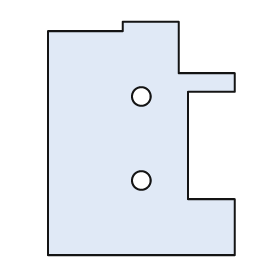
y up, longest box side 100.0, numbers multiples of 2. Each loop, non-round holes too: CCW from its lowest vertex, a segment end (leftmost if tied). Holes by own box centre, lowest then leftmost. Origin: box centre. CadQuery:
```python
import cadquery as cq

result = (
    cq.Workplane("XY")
    .moveTo(-40.0, -50.0)
    .lineTo(40.0, -50.0)
    .lineTo(40.0, -26.0)
    .lineTo(20.0, -26.0)
    .lineTo(20.0, 20.0)
    .lineTo(40.0, 20.0)
    .lineTo(40.0, 28.0)
    .lineTo(16.0, 28.0)
    .lineTo(16.0, 50.0)
    .lineTo(-8.0, 50.0)
    .lineTo(-8.0, 46.0)
    .lineTo(-40.0, 46.0)
    .close()
    .moveTo(0.0, -18.0)
    .circle(4.0)
    .moveTo(0.0, 18.0)
    .circle(4.0)
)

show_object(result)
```